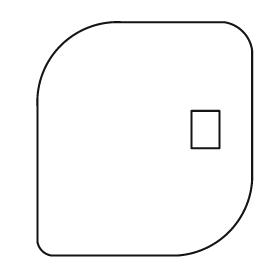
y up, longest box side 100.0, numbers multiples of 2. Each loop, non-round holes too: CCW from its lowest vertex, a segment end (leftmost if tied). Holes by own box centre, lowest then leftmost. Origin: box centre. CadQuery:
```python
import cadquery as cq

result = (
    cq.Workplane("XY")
    .moveTo(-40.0, -50.0)
    .lineTo(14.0, -50.0)
    .threePointArc((36.0, -40.0), (46.0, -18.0))
    .lineTo(46.0, 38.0)
    .threePointArc((42.0, 46.0), (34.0, 50.0))
    .lineTo(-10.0, 50.0)
    .threePointArc((-36.0, 40.0), (-46.0, 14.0))
    .lineTo(-46.0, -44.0)
    .threePointArc((-44.0, -48.0), (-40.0, -50.0))
    .close()
    .moveTo(20.0, -4.0)
    .lineTo(32.0, -4.0)
    .lineTo(32.0, 12.0)
    .lineTo(20.0, 12.0)
    .close()
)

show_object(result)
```